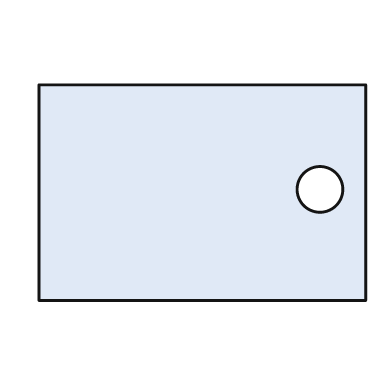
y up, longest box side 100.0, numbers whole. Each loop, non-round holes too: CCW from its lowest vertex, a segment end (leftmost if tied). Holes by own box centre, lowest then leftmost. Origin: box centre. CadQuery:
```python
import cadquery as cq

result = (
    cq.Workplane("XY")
    .moveTo(-50.0, -33.0)
    .lineTo(50.0, -33.0)
    .lineTo(50.0, 33.0)
    .lineTo(-50.0, 33.0)
    .close()
    .moveTo(36.0, 1.0)
    .circle(7.0)
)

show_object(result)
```